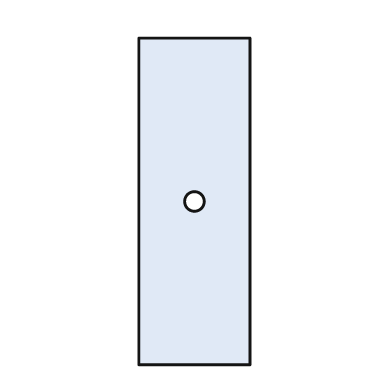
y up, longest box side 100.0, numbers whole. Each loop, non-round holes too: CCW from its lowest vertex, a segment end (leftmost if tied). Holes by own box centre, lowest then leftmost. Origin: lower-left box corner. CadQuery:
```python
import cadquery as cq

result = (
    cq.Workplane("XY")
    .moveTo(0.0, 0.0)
    .lineTo(34.0, 0.0)
    .lineTo(34.0, 100.0)
    .lineTo(0.0, 100.0)
    .close()
    .moveTo(17.0, 50.0)
    .circle(3.0)
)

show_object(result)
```